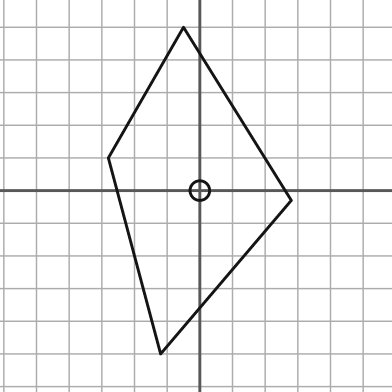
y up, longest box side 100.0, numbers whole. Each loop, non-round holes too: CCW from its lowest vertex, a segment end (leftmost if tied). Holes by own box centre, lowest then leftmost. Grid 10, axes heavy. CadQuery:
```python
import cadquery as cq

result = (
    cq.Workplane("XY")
    .moveTo(-12.0, -50.0)
    .lineTo(28.0, -3.0)
    .lineTo(-5.0, 50.0)
    .lineTo(-28.0, 10.0)
    .close()
    .moveTo(0.0, 0.0)
    .circle(3.0)
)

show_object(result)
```